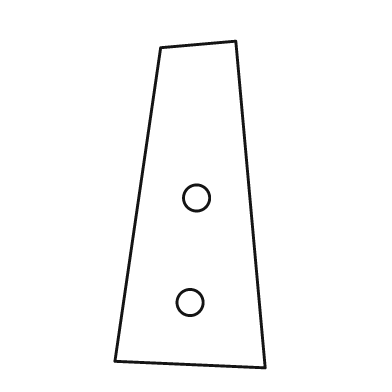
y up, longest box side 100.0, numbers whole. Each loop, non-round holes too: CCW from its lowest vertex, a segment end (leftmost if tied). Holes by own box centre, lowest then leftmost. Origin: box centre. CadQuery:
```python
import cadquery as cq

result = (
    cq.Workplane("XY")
    .moveTo(23.0, -50.0)
    .lineTo(14.0, 50.0)
    .lineTo(-9.0, 48.0)
    .lineTo(-23.0, -48.0)
    .close()
    .moveTo(0.0, -30.0)
    .circle(4.0)
    .moveTo(2.0, 2.0)
    .circle(4.0)
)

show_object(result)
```